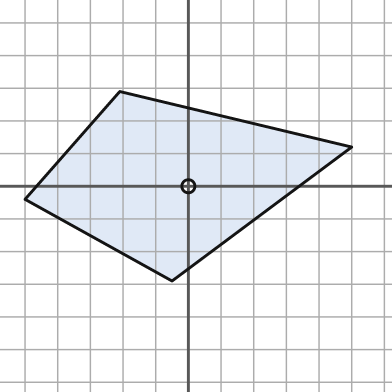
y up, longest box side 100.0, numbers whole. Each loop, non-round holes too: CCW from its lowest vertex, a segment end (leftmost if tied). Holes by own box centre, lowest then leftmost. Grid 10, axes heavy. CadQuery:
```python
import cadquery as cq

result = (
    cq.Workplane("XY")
    .moveTo(-5.0, -29.0)
    .lineTo(50.0, 12.0)
    .lineTo(-21.0, 29.0)
    .lineTo(-50.0, -4.0)
    .close()
    .moveTo(0.0, 0.0)
    .circle(2.0)
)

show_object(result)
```